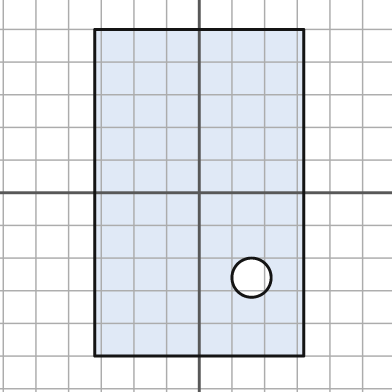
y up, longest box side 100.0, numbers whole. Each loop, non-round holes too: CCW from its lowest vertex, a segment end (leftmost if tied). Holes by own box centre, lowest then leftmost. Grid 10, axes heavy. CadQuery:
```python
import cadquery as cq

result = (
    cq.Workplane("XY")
    .moveTo(-32.0, -50.0)
    .lineTo(32.0, -50.0)
    .lineTo(32.0, 50.0)
    .lineTo(-32.0, 50.0)
    .close()
    .moveTo(16.0, -26.0)
    .circle(6.0)
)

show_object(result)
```